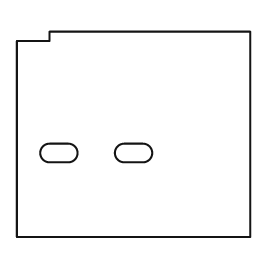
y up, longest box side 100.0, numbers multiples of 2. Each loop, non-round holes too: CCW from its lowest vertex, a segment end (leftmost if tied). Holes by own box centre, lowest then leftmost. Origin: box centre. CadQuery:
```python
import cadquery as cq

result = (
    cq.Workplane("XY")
    .moveTo(-50.0, -44.0)
    .lineTo(50.0, -44.0)
    .lineTo(50.0, 44.0)
    .lineTo(-36.0, 44.0)
    .lineTo(-36.0, 40.0)
    .lineTo(-50.0, 40.0)
    .close()
    .moveTo(-36.0, -12.0)
    .lineTo(-28.0, -12.0)
    .threePointArc((-24.0, -8.0), (-28.0, -4.0))
    .lineTo(-36.0, -4.0)
    .threePointArc((-40.0, -8.0), (-36.0, -12.0))
    .close()
    .moveTo(-4.0, -12.0)
    .lineTo(4.0, -12.0)
    .threePointArc((8.0, -8.0), (4.0, -4.0))
    .lineTo(-4.0, -4.0)
    .threePointArc((-8.0, -8.0), (-4.0, -12.0))
    .close()
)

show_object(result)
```